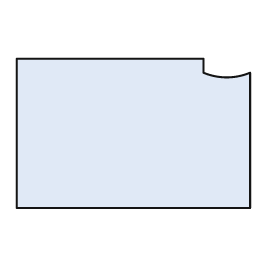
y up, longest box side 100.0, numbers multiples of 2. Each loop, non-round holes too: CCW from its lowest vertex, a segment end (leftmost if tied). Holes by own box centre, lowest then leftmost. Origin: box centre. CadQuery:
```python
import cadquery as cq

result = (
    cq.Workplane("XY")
    .moveTo(-50.0, -32.0)
    .lineTo(50.0, -32.0)
    .lineTo(50.0, 26.0)
    .threePointArc((40.0, 24.0), (30.0, 26.0))
    .lineTo(30.0, 32.0)
    .lineTo(-50.0, 32.0)
    .close()
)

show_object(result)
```